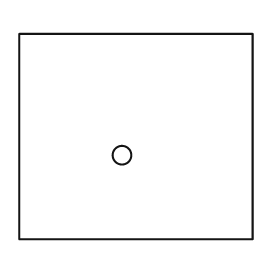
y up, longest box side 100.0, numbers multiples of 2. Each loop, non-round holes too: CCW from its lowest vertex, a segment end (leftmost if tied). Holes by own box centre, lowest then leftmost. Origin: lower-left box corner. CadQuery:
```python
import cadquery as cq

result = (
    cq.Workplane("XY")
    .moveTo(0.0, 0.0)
    .lineTo(100.0, 0.0)
    .lineTo(100.0, 88.0)
    .lineTo(0.0, 88.0)
    .close()
    .moveTo(44.0, 36.0)
    .circle(4.0)
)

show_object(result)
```